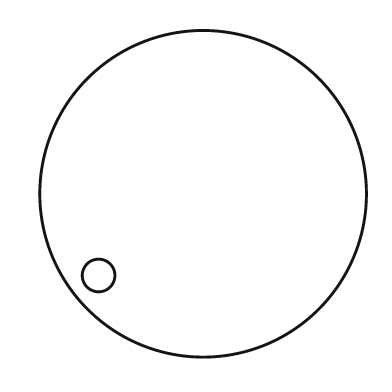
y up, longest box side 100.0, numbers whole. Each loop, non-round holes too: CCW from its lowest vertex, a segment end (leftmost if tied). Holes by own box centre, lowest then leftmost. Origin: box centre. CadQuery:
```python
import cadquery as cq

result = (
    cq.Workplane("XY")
    .moveTo(0.0, 0.0)
    .circle(50.0)
    .moveTo(-32.0, -25.0)
    .circle(5.0)
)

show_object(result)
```